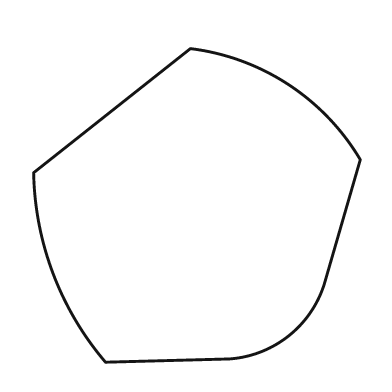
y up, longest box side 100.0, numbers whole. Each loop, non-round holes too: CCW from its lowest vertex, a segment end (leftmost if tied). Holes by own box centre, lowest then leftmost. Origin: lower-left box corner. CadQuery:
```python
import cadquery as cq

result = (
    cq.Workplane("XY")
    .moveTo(22.0, 0.0)
    .lineTo(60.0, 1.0)
    .threePointArc((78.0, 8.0), (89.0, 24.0))
    .lineTo(100.0, 62.0)
    .threePointArc((78.0, 85.0), (48.0, 96.0))
    .lineTo(0.0, 58.0)
    .threePointArc((6.0, 27.0), (22.0, 0.0))
    .close()
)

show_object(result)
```